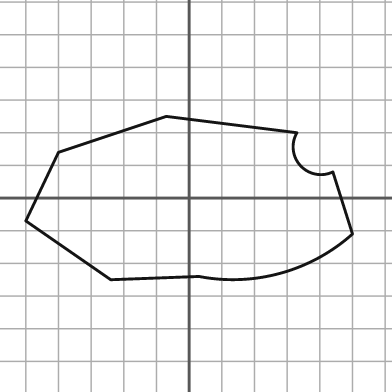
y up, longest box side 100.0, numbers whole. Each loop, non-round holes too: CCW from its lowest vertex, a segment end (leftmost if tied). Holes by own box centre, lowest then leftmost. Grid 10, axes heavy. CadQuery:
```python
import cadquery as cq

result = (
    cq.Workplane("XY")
    .moveTo(-24.0, -25.0)
    .lineTo(3.0, -24.0)
    .threePointArc((28.0, -23.0), (50.0, -11.0))
    .lineTo(44.0, 8.0)
    .threePointArc((34.0, 10.0), (33.0, 20.0))
    .lineTo(-7.0, 25.0)
    .lineTo(-40.0, 14.0)
    .lineTo(-50.0, -7.0)
    .close()
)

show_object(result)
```